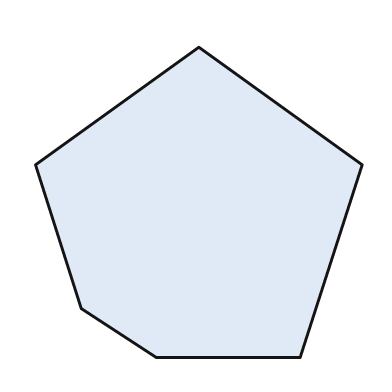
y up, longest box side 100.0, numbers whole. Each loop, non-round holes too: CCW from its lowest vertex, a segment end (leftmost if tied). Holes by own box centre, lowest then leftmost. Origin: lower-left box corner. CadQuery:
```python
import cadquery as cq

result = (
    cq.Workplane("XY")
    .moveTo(37.0, 0.0)
    .lineTo(81.0, 0.0)
    .lineTo(100.0, 59.0)
    .lineTo(50.0, 95.0)
    .lineTo(0.0, 59.0)
    .lineTo(14.0, 15.0)
    .close()
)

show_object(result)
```